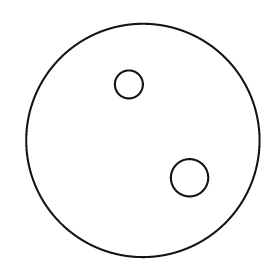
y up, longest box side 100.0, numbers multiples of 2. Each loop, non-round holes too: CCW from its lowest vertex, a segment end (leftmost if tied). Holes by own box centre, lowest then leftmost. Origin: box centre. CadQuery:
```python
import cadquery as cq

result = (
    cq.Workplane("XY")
    .moveTo(0.0, 0.0)
    .circle(50.0)
    .moveTo(20.0, -16.0)
    .circle(8.0)
    .moveTo(-6.0, 24.0)
    .circle(6.0)
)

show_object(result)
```